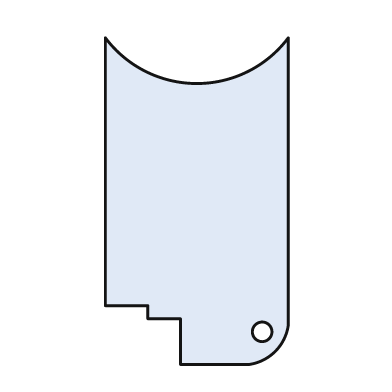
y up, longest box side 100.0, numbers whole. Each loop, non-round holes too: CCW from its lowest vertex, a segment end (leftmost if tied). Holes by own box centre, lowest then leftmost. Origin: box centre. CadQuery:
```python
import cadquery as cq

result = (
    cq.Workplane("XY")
    .moveTo(-5.0, -50.0)
    .lineTo(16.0, -50.0)
    .threePointArc((24.0, -46.0), (28.0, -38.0))
    .lineTo(28.0, 50.0)
    .threePointArc((0.0, 36.0), (-28.0, 50.0))
    .lineTo(-28.0, -32.0)
    .lineTo(-15.0, -32.0)
    .lineTo(-15.0, -36.0)
    .lineTo(-5.0, -36.0)
    .close()
    .moveTo(20.0, -40.0)
    .circle(3.0)
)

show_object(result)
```